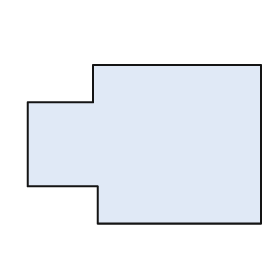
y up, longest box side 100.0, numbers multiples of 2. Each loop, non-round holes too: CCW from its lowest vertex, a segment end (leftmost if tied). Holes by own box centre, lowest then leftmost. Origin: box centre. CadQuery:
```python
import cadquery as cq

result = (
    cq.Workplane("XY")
    .moveTo(-20.0, -34.0)
    .lineTo(50.0, -34.0)
    .lineTo(50.0, 34.0)
    .lineTo(-22.0, 34.0)
    .lineTo(-22.0, 18.0)
    .lineTo(-50.0, 18.0)
    .lineTo(-50.0, -18.0)
    .lineTo(-20.0, -18.0)
    .close()
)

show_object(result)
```